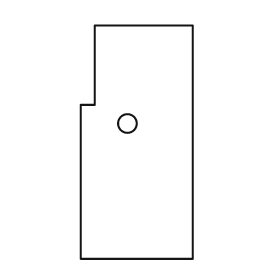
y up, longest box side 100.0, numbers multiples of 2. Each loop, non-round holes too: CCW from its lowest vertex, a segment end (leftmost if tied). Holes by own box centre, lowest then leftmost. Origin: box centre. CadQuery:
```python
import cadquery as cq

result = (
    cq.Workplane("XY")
    .moveTo(-24.0, -50.0)
    .lineTo(24.0, -50.0)
    .lineTo(24.0, 50.0)
    .lineTo(-18.0, 50.0)
    .lineTo(-18.0, 16.0)
    .lineTo(-24.0, 16.0)
    .close()
    .moveTo(-4.0, 8.0)
    .circle(4.0)
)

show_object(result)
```